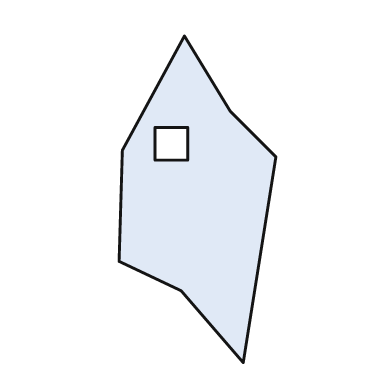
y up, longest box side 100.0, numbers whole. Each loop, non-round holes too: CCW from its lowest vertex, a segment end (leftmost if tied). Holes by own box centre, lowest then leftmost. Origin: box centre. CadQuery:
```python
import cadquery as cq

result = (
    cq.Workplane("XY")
    .moveTo(14.0, -50.0)
    .lineTo(24.0, 13.0)
    .lineTo(10.0, 27.0)
    .lineTo(-4.0, 50.0)
    .lineTo(-23.0, 15.0)
    .lineTo(-24.0, -19.0)
    .lineTo(-5.0, -28.0)
    .close()
    .moveTo(-13.0, 12.0)
    .lineTo(-3.0, 12.0)
    .lineTo(-3.0, 22.0)
    .lineTo(-13.0, 22.0)
    .close()
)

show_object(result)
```